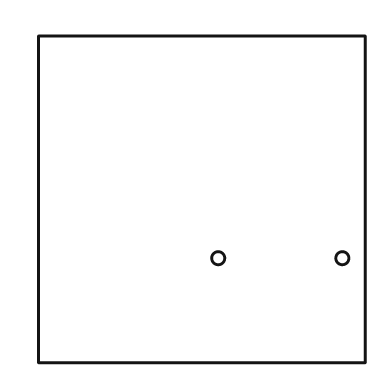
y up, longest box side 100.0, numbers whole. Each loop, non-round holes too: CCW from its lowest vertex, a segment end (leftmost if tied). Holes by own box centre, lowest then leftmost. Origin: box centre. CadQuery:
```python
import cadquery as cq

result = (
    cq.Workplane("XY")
    .moveTo(-50.0, -50.0)
    .lineTo(50.0, -50.0)
    .lineTo(50.0, 50.0)
    .lineTo(-50.0, 50.0)
    .close()
    .moveTo(5.0, -18.0)
    .circle(2.0)
    .moveTo(43.0, -18.0)
    .circle(2.0)
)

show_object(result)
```